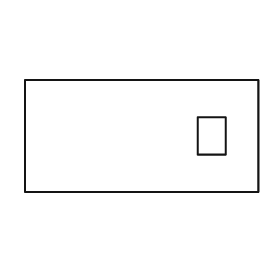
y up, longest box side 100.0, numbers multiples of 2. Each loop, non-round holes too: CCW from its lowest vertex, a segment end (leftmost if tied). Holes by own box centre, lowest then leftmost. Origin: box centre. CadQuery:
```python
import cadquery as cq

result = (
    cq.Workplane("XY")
    .moveTo(-50.0, -24.0)
    .lineTo(50.0, -24.0)
    .lineTo(50.0, 24.0)
    .lineTo(-50.0, 24.0)
    .close()
    .moveTo(24.0, -8.0)
    .lineTo(36.0, -8.0)
    .lineTo(36.0, 8.0)
    .lineTo(24.0, 8.0)
    .close()
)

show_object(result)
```